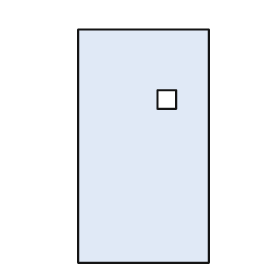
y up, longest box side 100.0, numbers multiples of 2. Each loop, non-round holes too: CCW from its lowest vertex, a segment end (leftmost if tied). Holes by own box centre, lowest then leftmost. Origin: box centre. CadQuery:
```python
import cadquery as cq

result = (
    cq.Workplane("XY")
    .moveTo(-28.0, -50.0)
    .lineTo(28.0, -50.0)
    .lineTo(28.0, 50.0)
    .lineTo(-28.0, 50.0)
    .close()
    .moveTo(6.0, 16.0)
    .lineTo(14.0, 16.0)
    .lineTo(14.0, 24.0)
    .lineTo(6.0, 24.0)
    .close()
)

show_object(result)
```